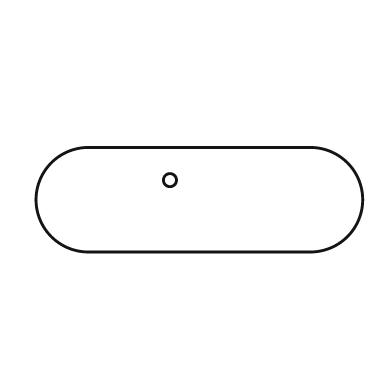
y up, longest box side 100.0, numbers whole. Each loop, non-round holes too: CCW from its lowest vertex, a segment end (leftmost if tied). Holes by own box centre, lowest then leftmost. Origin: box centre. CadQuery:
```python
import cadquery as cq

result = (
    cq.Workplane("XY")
    .moveTo(-34.0, -16.0)
    .lineTo(34.0, -16.0)
    .threePointArc((50.0, 0.0), (34.0, 16.0))
    .lineTo(-34.0, 16.0)
    .threePointArc((-50.0, 0.0), (-34.0, -16.0))
    .close()
    .moveTo(-9.0, 6.0)
    .circle(2.0)
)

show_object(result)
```